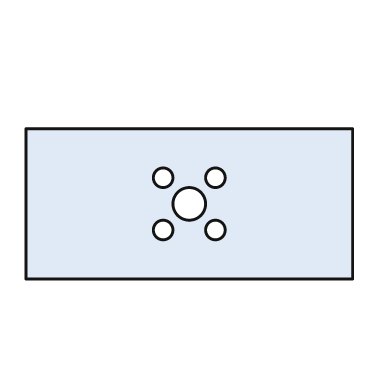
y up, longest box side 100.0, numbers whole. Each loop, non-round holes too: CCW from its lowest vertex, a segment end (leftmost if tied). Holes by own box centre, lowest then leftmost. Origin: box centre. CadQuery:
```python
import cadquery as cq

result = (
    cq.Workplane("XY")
    .moveTo(-50.0, -23.0)
    .lineTo(50.0, -23.0)
    .lineTo(50.0, 23.0)
    .lineTo(-50.0, 23.0)
    .close()
    .moveTo(-8.0, -8.0)
    .circle(3.0)
    .moveTo(8.0, -8.0)
    .circle(3.0)
    .moveTo(0.0, 0.0)
    .circle(5.0)
    .moveTo(-8.0, 8.0)
    .circle(3.0)
    .moveTo(8.0, 8.0)
    .circle(3.0)
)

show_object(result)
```